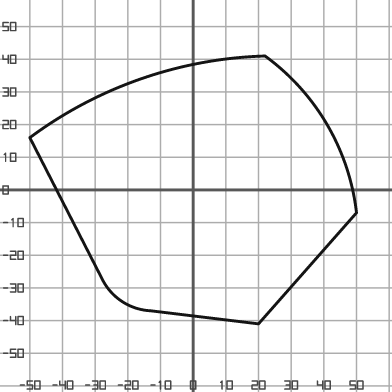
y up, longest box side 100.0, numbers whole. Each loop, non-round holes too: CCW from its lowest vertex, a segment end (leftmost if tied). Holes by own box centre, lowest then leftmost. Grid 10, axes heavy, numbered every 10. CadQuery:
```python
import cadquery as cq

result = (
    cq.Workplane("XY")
    .moveTo(20.0, -41.0)
    .lineTo(50.0, -7.0)
    .threePointArc((41.0, 20.0), (22.0, 41.0))
    .threePointArc((-16.0, 34.0), (-50.0, 16.0))
    .lineTo(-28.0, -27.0)
    .threePointArc((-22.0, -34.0), (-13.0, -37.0))
    .close()
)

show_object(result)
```